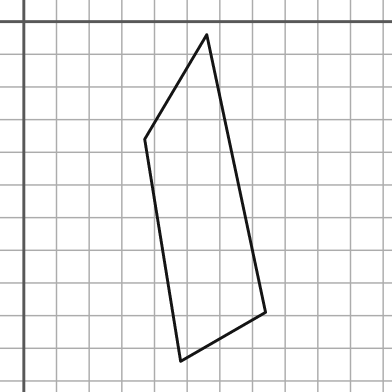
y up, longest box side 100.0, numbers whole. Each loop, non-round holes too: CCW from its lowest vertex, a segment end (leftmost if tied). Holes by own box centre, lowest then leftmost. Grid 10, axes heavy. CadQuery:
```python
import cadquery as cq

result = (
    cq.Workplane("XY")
    .moveTo(48.0, -104.0)
    .lineTo(74.0, -89.0)
    .lineTo(56.0, -4.0)
    .lineTo(37.0, -36.0)
    .close()
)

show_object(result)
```